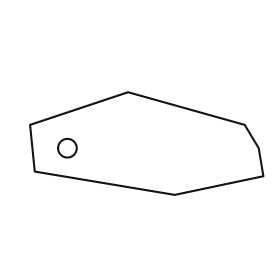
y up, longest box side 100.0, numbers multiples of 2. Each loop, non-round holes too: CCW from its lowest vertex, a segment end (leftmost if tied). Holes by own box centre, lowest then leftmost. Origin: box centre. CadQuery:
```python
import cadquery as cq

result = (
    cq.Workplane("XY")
    .moveTo(12.0, -22.0)
    .lineTo(50.0, -14.0)
    .lineTo(48.0, -2.0)
    .lineTo(42.0, 8.0)
    .lineTo(-8.0, 22.0)
    .lineTo(-50.0, 8.0)
    .lineTo(-48.0, -12.0)
    .close()
    .moveTo(-34.0, -2.0)
    .circle(4.0)
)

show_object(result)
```